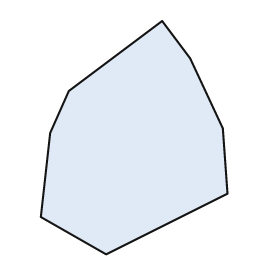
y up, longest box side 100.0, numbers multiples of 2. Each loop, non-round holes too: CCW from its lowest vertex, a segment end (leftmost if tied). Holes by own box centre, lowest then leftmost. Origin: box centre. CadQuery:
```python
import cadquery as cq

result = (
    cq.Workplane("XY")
    .moveTo(-12.0, -50.0)
    .lineTo(40.0, -24.0)
    .lineTo(38.0, 4.0)
    .lineTo(24.0, 34.0)
    .lineTo(12.0, 50.0)
    .lineTo(-28.0, 20.0)
    .lineTo(-36.0, 2.0)
    .lineTo(-40.0, -34.0)
    .close()
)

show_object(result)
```